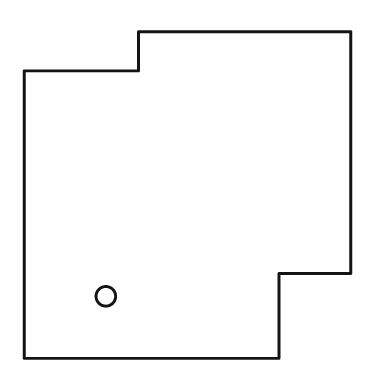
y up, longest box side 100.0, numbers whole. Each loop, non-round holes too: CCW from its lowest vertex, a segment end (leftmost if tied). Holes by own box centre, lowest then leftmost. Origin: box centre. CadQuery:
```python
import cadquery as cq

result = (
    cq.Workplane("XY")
    .moveTo(-50.0, -50.0)
    .lineTo(28.0, -50.0)
    .lineTo(28.0, -24.0)
    .lineTo(50.0, -24.0)
    .lineTo(50.0, 50.0)
    .lineTo(-15.0, 50.0)
    .lineTo(-15.0, 38.0)
    .lineTo(-50.0, 38.0)
    .close()
    .moveTo(-25.0, -31.0)
    .circle(3.0)
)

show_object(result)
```